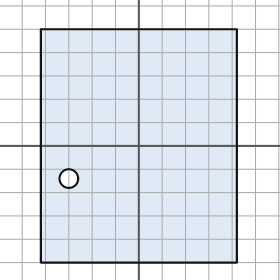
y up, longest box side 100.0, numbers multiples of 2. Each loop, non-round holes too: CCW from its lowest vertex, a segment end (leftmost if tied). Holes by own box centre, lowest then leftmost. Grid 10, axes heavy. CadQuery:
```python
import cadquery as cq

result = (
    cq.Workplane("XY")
    .moveTo(-42.0, -50.0)
    .lineTo(42.0, -50.0)
    .lineTo(42.0, 50.0)
    .lineTo(-42.0, 50.0)
    .close()
    .moveTo(-30.0, -14.0)
    .circle(4.0)
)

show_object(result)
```